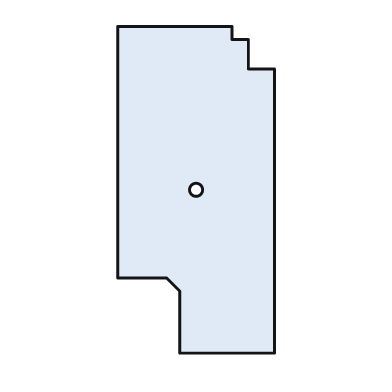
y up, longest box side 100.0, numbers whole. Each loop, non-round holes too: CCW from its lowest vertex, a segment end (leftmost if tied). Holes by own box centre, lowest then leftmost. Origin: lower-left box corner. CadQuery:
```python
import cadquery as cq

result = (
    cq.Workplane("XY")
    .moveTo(19.0, 0.0)
    .lineTo(48.0, 0.0)
    .lineTo(48.0, 87.0)
    .lineTo(40.0, 87.0)
    .lineTo(40.0, 96.0)
    .lineTo(35.0, 96.0)
    .lineTo(35.0, 100.0)
    .lineTo(0.0, 100.0)
    .lineTo(0.0, 23.0)
    .lineTo(15.0, 23.0)
    .lineTo(19.0, 19.0)
    .close()
    .moveTo(24.0, 50.0)
    .circle(2.0)
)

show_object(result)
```